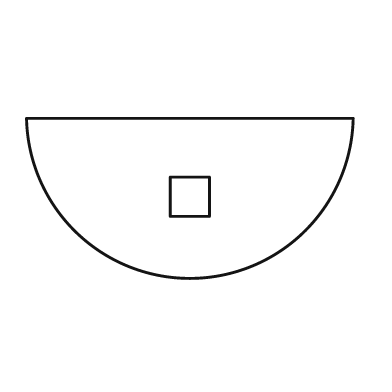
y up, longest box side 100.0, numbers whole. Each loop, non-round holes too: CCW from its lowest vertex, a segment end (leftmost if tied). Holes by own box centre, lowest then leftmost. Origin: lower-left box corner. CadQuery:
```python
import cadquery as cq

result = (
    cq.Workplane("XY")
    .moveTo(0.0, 49.0)
    .threePointArc((50.0, 0.0), (100.0, 49.0))
    .close()
    .moveTo(44.0, 19.0)
    .lineTo(56.0, 19.0)
    .lineTo(56.0, 31.0)
    .lineTo(44.0, 31.0)
    .close()
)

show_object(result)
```